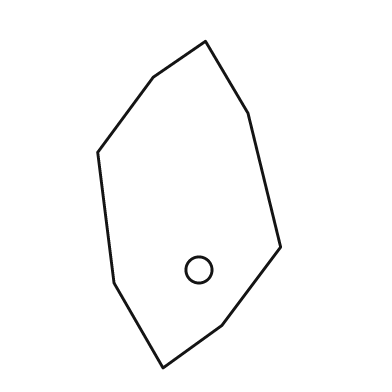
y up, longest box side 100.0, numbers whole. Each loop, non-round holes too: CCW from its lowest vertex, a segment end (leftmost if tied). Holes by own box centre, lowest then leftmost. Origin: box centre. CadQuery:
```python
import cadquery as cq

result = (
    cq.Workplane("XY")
    .moveTo(-8.0, -50.0)
    .lineTo(10.0, -37.0)
    .lineTo(28.0, -13.0)
    .lineTo(18.0, 28.0)
    .lineTo(5.0, 50.0)
    .lineTo(-11.0, 39.0)
    .lineTo(-28.0, 16.0)
    .lineTo(-23.0, -24.0)
    .close()
    .moveTo(3.0, -20.0)
    .circle(4.0)
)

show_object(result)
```